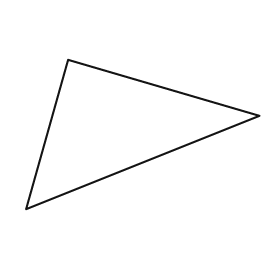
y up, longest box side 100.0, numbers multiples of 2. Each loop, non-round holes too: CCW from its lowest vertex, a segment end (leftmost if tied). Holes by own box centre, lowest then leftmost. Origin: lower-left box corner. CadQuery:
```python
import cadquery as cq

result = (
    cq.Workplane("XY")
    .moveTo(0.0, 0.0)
    .lineTo(100.0, 40.0)
    .lineTo(18.0, 64.0)
    .close()
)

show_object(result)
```